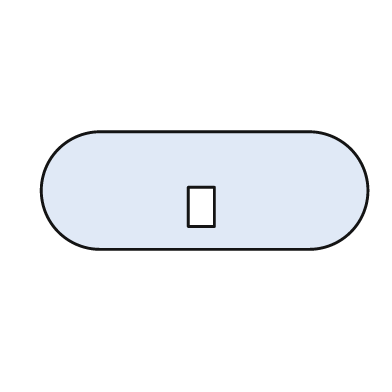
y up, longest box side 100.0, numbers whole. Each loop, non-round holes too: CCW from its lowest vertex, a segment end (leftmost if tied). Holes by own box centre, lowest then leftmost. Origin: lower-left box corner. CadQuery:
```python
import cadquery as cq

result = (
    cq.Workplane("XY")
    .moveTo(18.0, 0.0)
    .lineTo(82.0, 0.0)
    .threePointArc((100.0, 18.0), (82.0, 36.0))
    .lineTo(18.0, 36.0)
    .threePointArc((0.0, 18.0), (18.0, 0.0))
    .close()
    .moveTo(45.0, 7.0)
    .lineTo(53.0, 7.0)
    .lineTo(53.0, 19.0)
    .lineTo(45.0, 19.0)
    .close()
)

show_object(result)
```